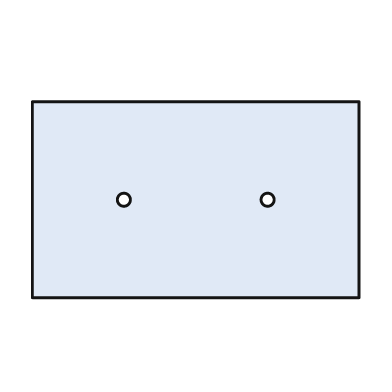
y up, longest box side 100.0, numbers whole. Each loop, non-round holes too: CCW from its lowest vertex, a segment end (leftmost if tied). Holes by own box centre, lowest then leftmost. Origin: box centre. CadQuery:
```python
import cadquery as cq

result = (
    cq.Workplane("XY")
    .moveTo(-50.0, -30.0)
    .lineTo(50.0, -30.0)
    .lineTo(50.0, 30.0)
    .lineTo(-50.0, 30.0)
    .close()
    .moveTo(-22.0, 0.0)
    .circle(2.0)
    .moveTo(22.0, 0.0)
    .circle(2.0)
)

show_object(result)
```